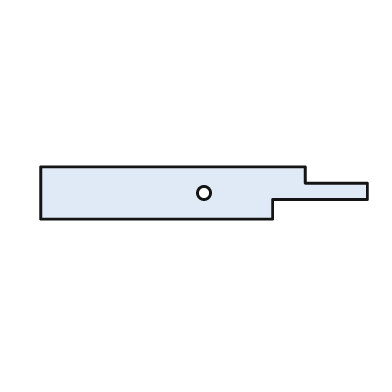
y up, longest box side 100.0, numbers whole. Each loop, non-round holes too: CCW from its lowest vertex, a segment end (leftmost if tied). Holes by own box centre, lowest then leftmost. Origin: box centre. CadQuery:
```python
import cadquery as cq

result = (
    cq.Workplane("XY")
    .moveTo(-50.0, -8.0)
    .lineTo(21.0, -8.0)
    .lineTo(21.0, -2.0)
    .lineTo(50.0, -2.0)
    .lineTo(50.0, 3.0)
    .lineTo(31.0, 3.0)
    .lineTo(31.0, 8.0)
    .lineTo(-50.0, 8.0)
    .close()
    .moveTo(0.0, 0.0)
    .circle(2.0)
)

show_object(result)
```